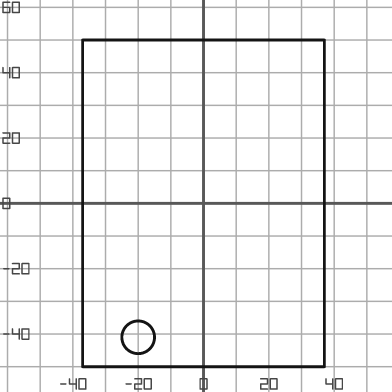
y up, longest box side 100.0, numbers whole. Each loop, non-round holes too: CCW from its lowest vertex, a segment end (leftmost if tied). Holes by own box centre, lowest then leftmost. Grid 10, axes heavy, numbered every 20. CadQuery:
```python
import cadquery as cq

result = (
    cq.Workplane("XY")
    .moveTo(-37.0, -50.0)
    .lineTo(37.0, -50.0)
    .lineTo(37.0, 50.0)
    .lineTo(-37.0, 50.0)
    .close()
    .moveTo(-20.0, -41.0)
    .circle(5.0)
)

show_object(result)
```